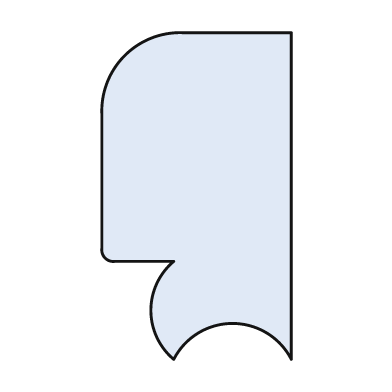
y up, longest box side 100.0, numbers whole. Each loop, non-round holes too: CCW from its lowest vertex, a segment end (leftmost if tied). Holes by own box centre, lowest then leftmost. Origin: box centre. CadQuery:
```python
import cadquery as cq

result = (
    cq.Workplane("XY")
    .moveTo(-7.0, -50.0)
    .threePointArc((11.0, -39.0), (29.0, -50.0))
    .lineTo(29.0, 50.0)
    .lineTo(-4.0, 50.0)
    .threePointArc((-22.0, 43.0), (-29.0, 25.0))
    .lineTo(-29.0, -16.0)
    .threePointArc((-28.0, -19.0), (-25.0, -20.0))
    .lineTo(-7.0, -20.0)
    .threePointArc((-14.0, -35.0), (-7.0, -50.0))
    .close()
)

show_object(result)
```